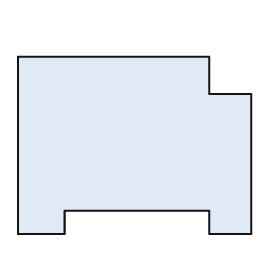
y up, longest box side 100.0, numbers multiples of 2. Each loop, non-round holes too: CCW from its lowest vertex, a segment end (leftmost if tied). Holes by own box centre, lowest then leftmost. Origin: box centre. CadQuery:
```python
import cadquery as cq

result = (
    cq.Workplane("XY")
    .moveTo(-50.0, -38.0)
    .lineTo(-30.0, -38.0)
    .lineTo(-30.0, -28.0)
    .lineTo(32.0, -28.0)
    .lineTo(32.0, -38.0)
    .lineTo(50.0, -38.0)
    .lineTo(50.0, 22.0)
    .lineTo(32.0, 22.0)
    .lineTo(32.0, 38.0)
    .lineTo(-50.0, 38.0)
    .close()
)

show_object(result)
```